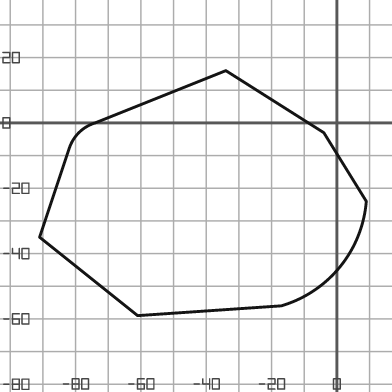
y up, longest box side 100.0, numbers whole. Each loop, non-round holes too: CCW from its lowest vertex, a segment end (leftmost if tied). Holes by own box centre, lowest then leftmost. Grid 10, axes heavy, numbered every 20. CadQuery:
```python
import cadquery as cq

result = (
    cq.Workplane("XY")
    .moveTo(-61.0, -59.0)
    .lineTo(-17.0, -56.0)
    .threePointArc((1.0, -44.0), (9.0, -24.0))
    .lineTo(-4.0, -3.0)
    .lineTo(-34.0, 16.0)
    .lineTo(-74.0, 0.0)
    .threePointArc((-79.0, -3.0), (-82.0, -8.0))
    .lineTo(-91.0, -35.0)
    .close()
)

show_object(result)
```